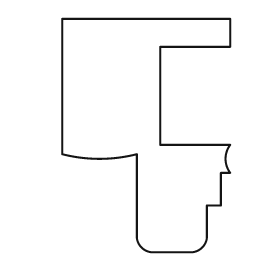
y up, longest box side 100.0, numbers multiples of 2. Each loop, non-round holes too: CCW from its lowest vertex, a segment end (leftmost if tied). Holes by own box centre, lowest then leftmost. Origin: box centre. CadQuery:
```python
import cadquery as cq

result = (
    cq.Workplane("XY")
    .moveTo(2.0, -50.0)
    .lineTo(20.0, -50.0)
    .threePointArc((24.0, -48.0), (26.0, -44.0))
    .lineTo(26.0, -30.0)
    .lineTo(32.0, -30.0)
    .lineTo(32.0, -16.0)
    .lineTo(36.0, -16.0)
    .threePointArc((34.0, -10.0), (36.0, -4.0))
    .lineTo(6.0, -4.0)
    .lineTo(6.0, 38.0)
    .lineTo(36.0, 38.0)
    .lineTo(36.0, 50.0)
    .lineTo(-36.0, 50.0)
    .lineTo(-36.0, -8.0)
    .threePointArc((-20.0, -10.0), (-4.0, -8.0))
    .lineTo(-4.0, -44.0)
    .threePointArc((-2.0, -48.0), (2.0, -50.0))
    .close()
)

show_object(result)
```